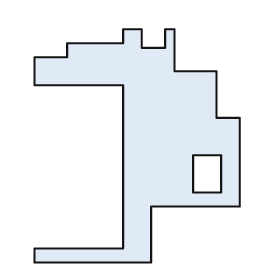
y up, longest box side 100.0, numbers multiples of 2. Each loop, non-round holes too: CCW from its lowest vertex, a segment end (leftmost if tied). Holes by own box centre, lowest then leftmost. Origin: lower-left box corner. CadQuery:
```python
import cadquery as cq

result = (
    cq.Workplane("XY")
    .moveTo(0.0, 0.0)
    .lineTo(50.0, 0.0)
    .lineTo(50.0, 24.0)
    .lineTo(88.0, 24.0)
    .lineTo(88.0, 62.0)
    .lineTo(78.0, 62.0)
    .lineTo(78.0, 82.0)
    .lineTo(60.0, 82.0)
    .lineTo(60.0, 100.0)
    .lineTo(56.0, 100.0)
    .lineTo(56.0, 92.0)
    .lineTo(46.0, 92.0)
    .lineTo(46.0, 100.0)
    .lineTo(38.0, 100.0)
    .lineTo(38.0, 94.0)
    .lineTo(14.0, 94.0)
    .lineTo(14.0, 88.0)
    .lineTo(0.0, 88.0)
    .lineTo(0.0, 76.0)
    .lineTo(38.0, 76.0)
    .lineTo(38.0, 6.0)
    .lineTo(0.0, 6.0)
    .close()
    .moveTo(68.0, 30.0)
    .lineTo(80.0, 30.0)
    .lineTo(80.0, 46.0)
    .lineTo(68.0, 46.0)
    .close()
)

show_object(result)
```